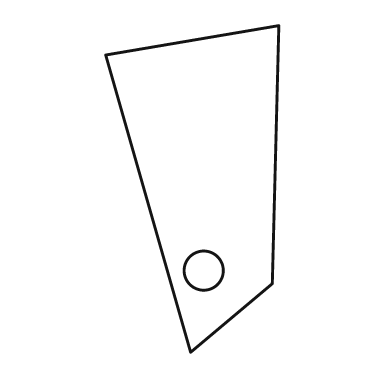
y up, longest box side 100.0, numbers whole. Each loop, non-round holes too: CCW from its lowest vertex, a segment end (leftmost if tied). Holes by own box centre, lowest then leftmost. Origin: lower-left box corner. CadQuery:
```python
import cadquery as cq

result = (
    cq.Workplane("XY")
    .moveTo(26.0, 0.0)
    .lineTo(51.0, 21.0)
    .lineTo(53.0, 100.0)
    .lineTo(0.0, 91.0)
    .close()
    .moveTo(30.0, 25.0)
    .circle(6.0)
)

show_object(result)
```